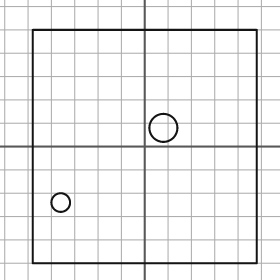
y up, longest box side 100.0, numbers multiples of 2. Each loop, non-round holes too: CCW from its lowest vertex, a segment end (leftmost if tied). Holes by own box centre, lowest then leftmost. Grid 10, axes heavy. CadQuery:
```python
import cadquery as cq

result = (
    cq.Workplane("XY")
    .moveTo(-48.0, -50.0)
    .lineTo(48.0, -50.0)
    .lineTo(48.0, 50.0)
    .lineTo(-48.0, 50.0)
    .close()
    .moveTo(-36.0, -24.0)
    .circle(4.0)
    .moveTo(8.0, 8.0)
    .circle(6.0)
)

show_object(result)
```